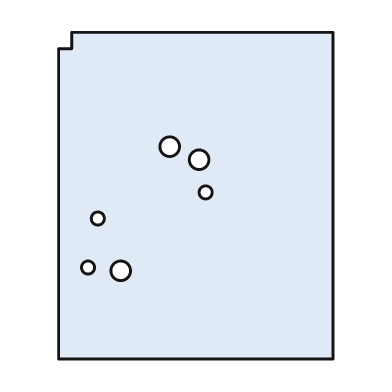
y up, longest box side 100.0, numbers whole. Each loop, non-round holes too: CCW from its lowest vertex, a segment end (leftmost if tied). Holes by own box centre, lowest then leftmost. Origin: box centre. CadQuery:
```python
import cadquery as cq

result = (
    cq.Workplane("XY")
    .moveTo(-42.0, -50.0)
    .lineTo(42.0, -50.0)
    .lineTo(42.0, 50.0)
    .lineTo(-38.0, 50.0)
    .lineTo(-38.0, 45.0)
    .lineTo(-42.0, 45.0)
    .close()
    .moveTo(-23.0, -23.0)
    .circle(3.0)
    .moveTo(-33.0, -22.0)
    .circle(2.0)
    .moveTo(-30.0, -7.0)
    .circle(2.0)
    .moveTo(3.0, 1.0)
    .circle(2.0)
    .moveTo(1.0, 11.0)
    .circle(3.0)
    .moveTo(-8.0, 15.0)
    .circle(3.0)
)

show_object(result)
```